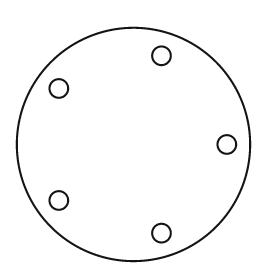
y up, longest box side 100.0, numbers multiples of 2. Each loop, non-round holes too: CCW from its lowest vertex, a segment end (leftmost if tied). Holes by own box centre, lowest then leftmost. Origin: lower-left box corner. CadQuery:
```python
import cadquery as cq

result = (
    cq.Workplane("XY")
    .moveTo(50.0, 50.0)
    .circle(50.0)
    .moveTo(62.0, 12.0)
    .circle(4.0)
    .moveTo(18.0, 26.0)
    .circle(4.0)
    .moveTo(90.0, 50.0)
    .circle(4.0)
    .moveTo(18.0, 74.0)
    .circle(4.0)
    .moveTo(62.0, 88.0)
    .circle(4.0)
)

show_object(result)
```